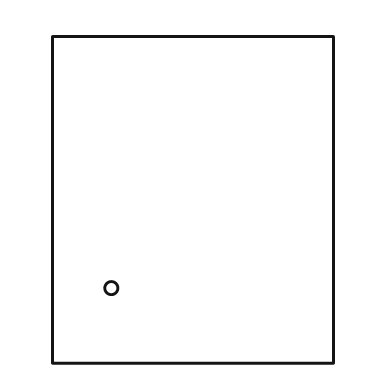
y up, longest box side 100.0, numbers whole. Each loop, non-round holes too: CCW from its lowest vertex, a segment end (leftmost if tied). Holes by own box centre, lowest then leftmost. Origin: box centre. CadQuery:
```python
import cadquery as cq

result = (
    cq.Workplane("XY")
    .moveTo(-43.0, -50.0)
    .lineTo(43.0, -50.0)
    .lineTo(43.0, 50.0)
    .lineTo(-43.0, 50.0)
    .close()
    .moveTo(-25.0, -27.0)
    .circle(2.0)
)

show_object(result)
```